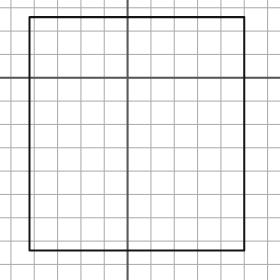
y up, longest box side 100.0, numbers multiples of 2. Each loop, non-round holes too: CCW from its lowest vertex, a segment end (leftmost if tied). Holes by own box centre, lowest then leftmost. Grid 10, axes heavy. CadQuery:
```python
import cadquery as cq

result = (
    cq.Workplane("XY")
    .moveTo(-42.0, -74.0)
    .lineTo(50.0, -74.0)
    .lineTo(50.0, 26.0)
    .lineTo(-42.0, 26.0)
    .close()
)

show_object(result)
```